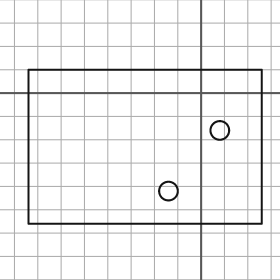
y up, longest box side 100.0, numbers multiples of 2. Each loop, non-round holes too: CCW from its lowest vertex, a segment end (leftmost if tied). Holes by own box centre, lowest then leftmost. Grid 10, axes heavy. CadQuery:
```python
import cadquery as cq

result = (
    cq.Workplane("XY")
    .moveTo(-74.0, -56.0)
    .lineTo(26.0, -56.0)
    .lineTo(26.0, 10.0)
    .lineTo(-74.0, 10.0)
    .close()
    .moveTo(-14.0, -42.0)
    .circle(4.0)
    .moveTo(8.0, -16.0)
    .circle(4.0)
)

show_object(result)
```